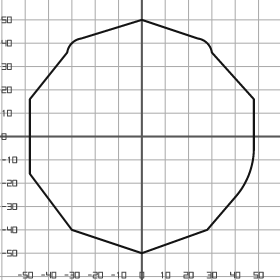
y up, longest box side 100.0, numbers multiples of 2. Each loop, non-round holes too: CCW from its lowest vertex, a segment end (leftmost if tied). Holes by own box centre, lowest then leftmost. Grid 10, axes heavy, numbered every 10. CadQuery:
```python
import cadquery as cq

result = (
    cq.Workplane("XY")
    .moveTo(0.0, -50.0)
    .lineTo(28.0, -40.0)
    .lineTo(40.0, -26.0)
    .threePointArc((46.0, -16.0), (48.0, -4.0))
    .lineTo(48.0, 16.0)
    .lineTo(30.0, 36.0)
    .threePointArc((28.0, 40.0), (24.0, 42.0))
    .lineTo(0.0, 50.0)
    .lineTo(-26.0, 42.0)
    .threePointArc((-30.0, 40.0), (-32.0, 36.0))
    .lineTo(-48.0, 16.0)
    .lineTo(-48.0, -16.0)
    .lineTo(-30.0, -40.0)
    .close()
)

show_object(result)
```